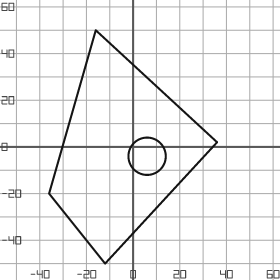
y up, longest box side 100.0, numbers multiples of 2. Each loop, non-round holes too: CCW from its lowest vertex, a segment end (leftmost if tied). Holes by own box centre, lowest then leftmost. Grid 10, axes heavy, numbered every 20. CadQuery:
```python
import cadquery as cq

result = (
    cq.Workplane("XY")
    .moveTo(-12.0, -50.0)
    .lineTo(36.0, 2.0)
    .lineTo(-16.0, 50.0)
    .lineTo(-36.0, -20.0)
    .close()
    .moveTo(6.0, -4.0)
    .circle(8.0)
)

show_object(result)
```